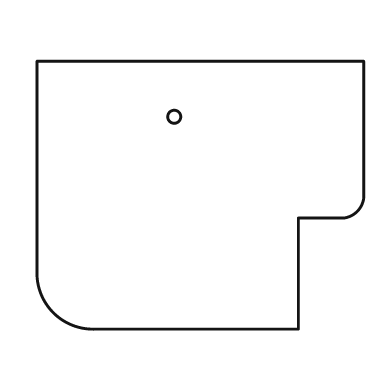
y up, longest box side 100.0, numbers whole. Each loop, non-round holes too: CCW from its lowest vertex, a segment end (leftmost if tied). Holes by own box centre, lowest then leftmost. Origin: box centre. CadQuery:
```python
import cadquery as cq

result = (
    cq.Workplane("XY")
    .moveTo(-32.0, -41.0)
    .lineTo(30.0, -41.0)
    .lineTo(30.0, -7.0)
    .lineTo(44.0, -7.0)
    .threePointArc((48.0, -5.0), (50.0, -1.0))
    .lineTo(50.0, 41.0)
    .lineTo(-50.0, 41.0)
    .lineTo(-50.0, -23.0)
    .threePointArc((-45.0, -36.0), (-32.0, -41.0))
    .close()
    .moveTo(-8.0, 24.0)
    .circle(2.0)
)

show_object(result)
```